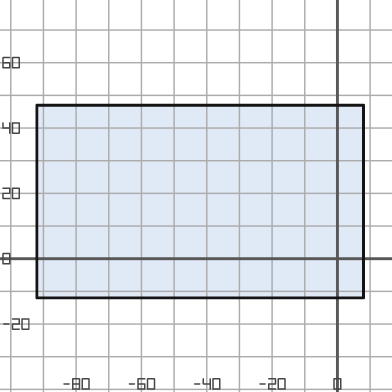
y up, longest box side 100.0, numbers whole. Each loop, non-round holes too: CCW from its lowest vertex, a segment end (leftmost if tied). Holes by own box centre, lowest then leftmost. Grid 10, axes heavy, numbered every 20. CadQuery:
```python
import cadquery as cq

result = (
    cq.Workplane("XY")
    .moveTo(-92.0, -12.0)
    .lineTo(8.0, -12.0)
    .lineTo(8.0, 47.0)
    .lineTo(-92.0, 47.0)
    .close()
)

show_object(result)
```